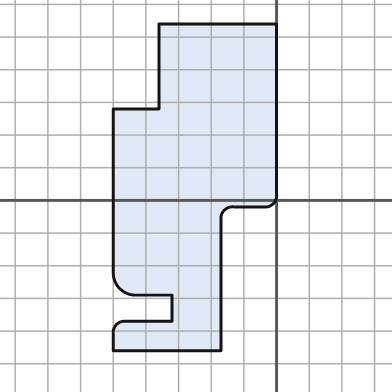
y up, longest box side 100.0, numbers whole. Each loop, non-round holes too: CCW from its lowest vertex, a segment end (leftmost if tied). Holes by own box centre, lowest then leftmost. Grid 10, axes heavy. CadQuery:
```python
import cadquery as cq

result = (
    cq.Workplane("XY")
    .moveTo(-50.0, -46.0)
    .lineTo(-17.0, -46.0)
    .lineTo(-17.0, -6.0)
    .threePointArc((-16.0, -3.0), (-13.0, -2.0))
    .lineTo(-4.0, -2.0)
    .threePointArc((-1.0, -1.0), (0.0, 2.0))
    .lineTo(0.0, 54.0)
    .lineTo(-36.0, 54.0)
    .lineTo(-36.0, 28.0)
    .lineTo(-50.0, 28.0)
    .lineTo(-50.0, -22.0)
    .threePointArc((-48.0, -27.0), (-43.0, -29.0))
    .lineTo(-32.0, -29.0)
    .lineTo(-32.0, -37.0)
    .lineTo(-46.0, -37.0)
    .threePointArc((-49.0, -38.0), (-50.0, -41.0))
    .close()
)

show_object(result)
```